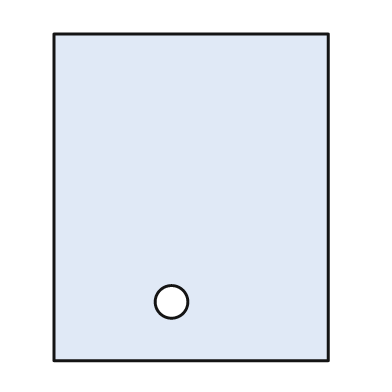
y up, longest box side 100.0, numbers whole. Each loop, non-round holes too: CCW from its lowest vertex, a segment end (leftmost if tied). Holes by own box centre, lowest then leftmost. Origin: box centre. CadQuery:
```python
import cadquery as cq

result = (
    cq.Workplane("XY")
    .moveTo(-42.0, -50.0)
    .lineTo(42.0, -50.0)
    .lineTo(42.0, 50.0)
    .lineTo(-42.0, 50.0)
    .close()
    .moveTo(-6.0, -32.0)
    .circle(5.0)
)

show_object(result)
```